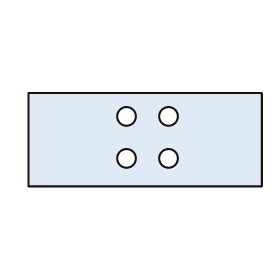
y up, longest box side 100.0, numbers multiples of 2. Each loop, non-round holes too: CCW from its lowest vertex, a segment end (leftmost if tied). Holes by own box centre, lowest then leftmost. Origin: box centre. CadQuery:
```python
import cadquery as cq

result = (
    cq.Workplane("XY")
    .moveTo(-50.0, -20.0)
    .lineTo(50.0, -20.0)
    .lineTo(50.0, 20.0)
    .lineTo(-50.0, 20.0)
    .close()
    .moveTo(-8.0, -8.0)
    .circle(4.0)
    .moveTo(10.0, -8.0)
    .circle(4.0)
    .moveTo(-8.0, 10.0)
    .circle(4.0)
    .moveTo(10.0, 10.0)
    .circle(4.0)
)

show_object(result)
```